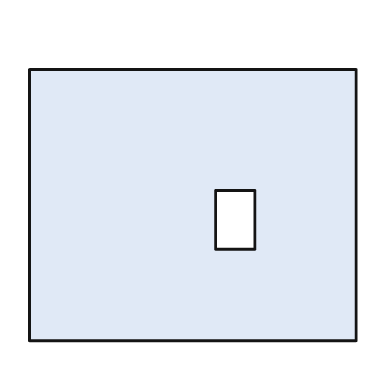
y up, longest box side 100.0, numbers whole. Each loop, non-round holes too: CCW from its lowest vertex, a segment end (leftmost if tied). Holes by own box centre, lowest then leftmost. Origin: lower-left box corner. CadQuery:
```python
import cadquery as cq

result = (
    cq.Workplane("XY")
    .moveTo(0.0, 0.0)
    .lineTo(100.0, 0.0)
    .lineTo(100.0, 83.0)
    .lineTo(0.0, 83.0)
    .close()
    .moveTo(57.0, 28.0)
    .lineTo(69.0, 28.0)
    .lineTo(69.0, 46.0)
    .lineTo(57.0, 46.0)
    .close()
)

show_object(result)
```